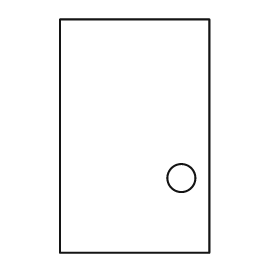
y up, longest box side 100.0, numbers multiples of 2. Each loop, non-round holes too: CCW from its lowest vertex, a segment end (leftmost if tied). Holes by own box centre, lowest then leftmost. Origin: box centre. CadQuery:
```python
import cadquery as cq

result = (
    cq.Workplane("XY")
    .moveTo(-32.0, -50.0)
    .lineTo(32.0, -50.0)
    .lineTo(32.0, 50.0)
    .lineTo(-32.0, 50.0)
    .close()
    .moveTo(20.0, -18.0)
    .circle(6.0)
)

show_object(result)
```